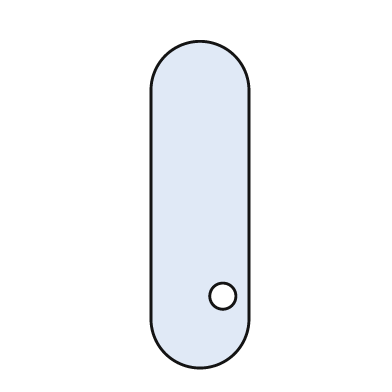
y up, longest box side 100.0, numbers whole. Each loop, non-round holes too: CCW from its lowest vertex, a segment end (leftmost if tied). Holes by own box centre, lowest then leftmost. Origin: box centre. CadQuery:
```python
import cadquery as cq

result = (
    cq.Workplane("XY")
    .moveTo(-15.0, -35.0)
    .threePointArc((0.0, -50.0), (15.0, -35.0))
    .lineTo(15.0, 35.0)
    .threePointArc((0.0, 50.0), (-15.0, 35.0))
    .close()
    .moveTo(7.0, -28.0)
    .circle(4.0)
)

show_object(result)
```